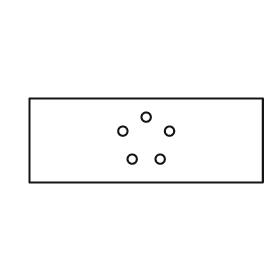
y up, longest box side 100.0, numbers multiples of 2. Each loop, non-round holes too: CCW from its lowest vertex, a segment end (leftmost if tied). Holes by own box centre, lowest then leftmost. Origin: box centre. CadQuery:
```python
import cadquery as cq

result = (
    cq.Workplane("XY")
    .moveTo(-50.0, -18.0)
    .lineTo(50.0, -18.0)
    .lineTo(50.0, 18.0)
    .lineTo(-50.0, 18.0)
    .close()
    .moveTo(-6.0, -8.0)
    .circle(2.0)
    .moveTo(6.0, -8.0)
    .circle(2.0)
    .moveTo(-10.0, 4.0)
    .circle(2.0)
    .moveTo(10.0, 4.0)
    .circle(2.0)
    .moveTo(0.0, 10.0)
    .circle(2.0)
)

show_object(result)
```